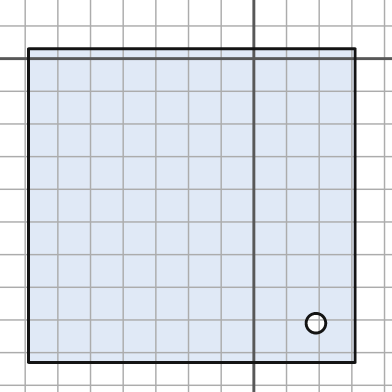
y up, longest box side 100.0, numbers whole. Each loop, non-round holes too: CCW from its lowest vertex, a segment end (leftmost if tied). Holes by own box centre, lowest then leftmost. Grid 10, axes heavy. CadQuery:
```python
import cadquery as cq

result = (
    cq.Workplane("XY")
    .moveTo(-69.0, -93.0)
    .lineTo(31.0, -93.0)
    .lineTo(31.0, 3.0)
    .lineTo(-69.0, 3.0)
    .close()
    .moveTo(19.0, -81.0)
    .circle(3.0)
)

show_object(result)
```